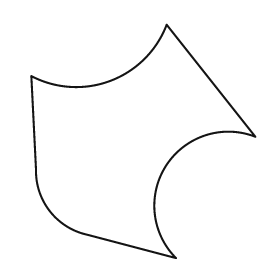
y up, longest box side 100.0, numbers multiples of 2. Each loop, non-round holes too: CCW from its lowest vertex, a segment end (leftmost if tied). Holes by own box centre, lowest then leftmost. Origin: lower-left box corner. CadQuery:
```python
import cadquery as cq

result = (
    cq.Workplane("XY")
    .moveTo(62.0, 0.0)
    .threePointArc((58.0, 40.0), (96.0, 52.0))
    .lineTo(58.0, 100.0)
    .threePointArc((34.0, 76.0), (0.0, 78.0))
    .lineTo(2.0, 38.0)
    .threePointArc((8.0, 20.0), (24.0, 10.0))
    .close()
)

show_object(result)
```